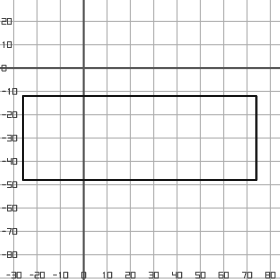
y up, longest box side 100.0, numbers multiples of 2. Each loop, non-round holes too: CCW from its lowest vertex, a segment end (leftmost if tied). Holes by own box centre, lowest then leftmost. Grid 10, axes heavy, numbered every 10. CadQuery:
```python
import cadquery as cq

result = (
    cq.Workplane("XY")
    .moveTo(-26.0, -48.0)
    .lineTo(74.0, -48.0)
    .lineTo(74.0, -12.0)
    .lineTo(-26.0, -12.0)
    .close()
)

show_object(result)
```